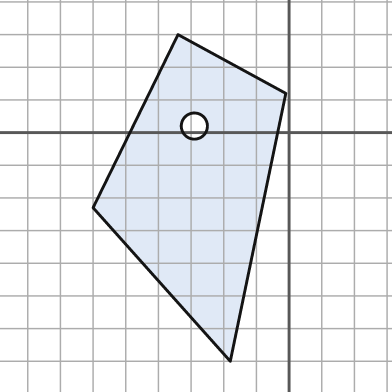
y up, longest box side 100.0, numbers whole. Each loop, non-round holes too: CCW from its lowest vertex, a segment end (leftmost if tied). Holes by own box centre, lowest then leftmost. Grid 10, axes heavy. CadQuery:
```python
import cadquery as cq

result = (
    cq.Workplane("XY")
    .moveTo(-18.0, -70.0)
    .lineTo(-1.0, 12.0)
    .lineTo(-34.0, 30.0)
    .lineTo(-60.0, -23.0)
    .close()
    .moveTo(-29.0, 2.0)
    .circle(4.0)
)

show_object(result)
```